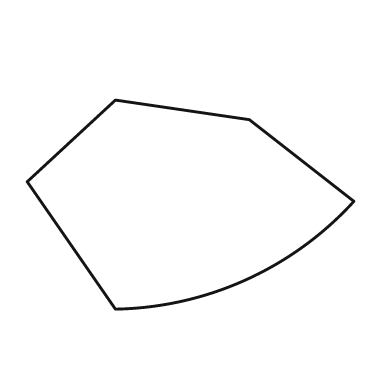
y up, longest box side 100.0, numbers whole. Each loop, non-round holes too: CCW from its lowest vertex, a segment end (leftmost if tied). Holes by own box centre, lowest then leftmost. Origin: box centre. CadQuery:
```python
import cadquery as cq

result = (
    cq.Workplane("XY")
    .moveTo(-23.0, -32.0)
    .threePointArc((17.0, -23.0), (50.0, 1.0))
    .lineTo(18.0, 26.0)
    .lineTo(-23.0, 32.0)
    .lineTo(-50.0, 7.0)
    .close()
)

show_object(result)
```